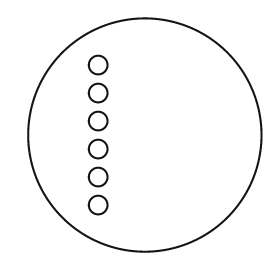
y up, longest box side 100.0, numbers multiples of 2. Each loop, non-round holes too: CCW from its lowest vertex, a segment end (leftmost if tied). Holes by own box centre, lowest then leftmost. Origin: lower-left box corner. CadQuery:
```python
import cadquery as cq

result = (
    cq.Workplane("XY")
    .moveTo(50.0, 50.0)
    .circle(50.0)
    .moveTo(30.0, 20.0)
    .circle(4.0)
    .moveTo(30.0, 32.0)
    .circle(4.0)
    .moveTo(30.0, 44.0)
    .circle(4.0)
    .moveTo(30.0, 56.0)
    .circle(4.0)
    .moveTo(30.0, 68.0)
    .circle(4.0)
    .moveTo(30.0, 80.0)
    .circle(4.0)
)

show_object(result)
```